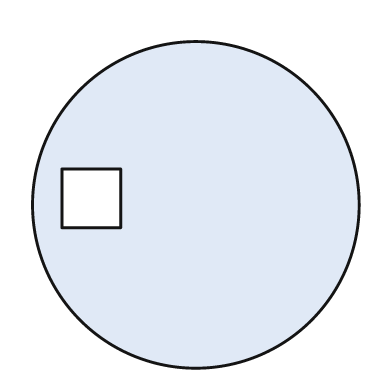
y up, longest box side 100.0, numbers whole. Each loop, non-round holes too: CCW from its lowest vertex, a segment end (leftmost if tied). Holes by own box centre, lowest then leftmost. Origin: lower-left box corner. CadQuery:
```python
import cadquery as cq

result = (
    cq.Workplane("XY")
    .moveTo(50.0, 50.0)
    .circle(50.0)
    .moveTo(9.0, 43.0)
    .lineTo(27.0, 43.0)
    .lineTo(27.0, 61.0)
    .lineTo(9.0, 61.0)
    .close()
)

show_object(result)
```